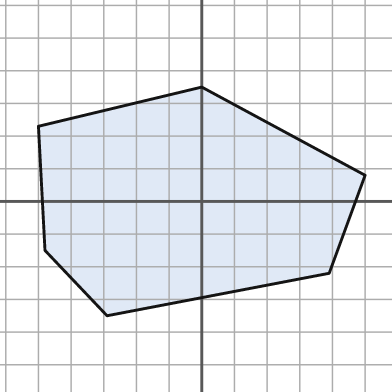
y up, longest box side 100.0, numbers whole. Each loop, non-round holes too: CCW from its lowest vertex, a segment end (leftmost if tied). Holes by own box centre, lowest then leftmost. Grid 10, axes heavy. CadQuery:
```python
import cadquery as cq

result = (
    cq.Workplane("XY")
    .moveTo(-29.0, -35.0)
    .lineTo(39.0, -22.0)
    .lineTo(50.0, 8.0)
    .lineTo(0.0, 35.0)
    .lineTo(-50.0, 23.0)
    .lineTo(-48.0, -15.0)
    .close()
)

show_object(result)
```